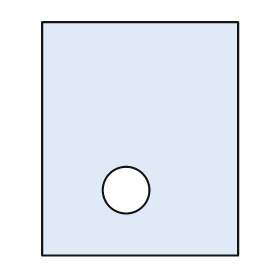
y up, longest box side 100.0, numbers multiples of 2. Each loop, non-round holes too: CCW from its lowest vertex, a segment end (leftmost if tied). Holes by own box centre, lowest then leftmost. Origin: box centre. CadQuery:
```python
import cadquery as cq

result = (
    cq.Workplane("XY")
    .moveTo(-42.0, -50.0)
    .lineTo(42.0, -50.0)
    .lineTo(42.0, 50.0)
    .lineTo(-42.0, 50.0)
    .close()
    .moveTo(-6.0, -22.0)
    .circle(10.0)
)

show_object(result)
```